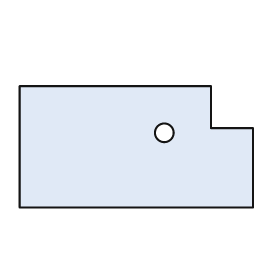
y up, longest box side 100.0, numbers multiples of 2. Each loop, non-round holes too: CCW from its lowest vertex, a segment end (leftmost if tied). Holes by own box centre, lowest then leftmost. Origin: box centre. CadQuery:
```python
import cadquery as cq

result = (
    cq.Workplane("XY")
    .moveTo(-50.0, -26.0)
    .lineTo(50.0, -26.0)
    .lineTo(50.0, 8.0)
    .lineTo(32.0, 8.0)
    .lineTo(32.0, 26.0)
    .lineTo(-50.0, 26.0)
    .close()
    .moveTo(12.0, 6.0)
    .circle(4.0)
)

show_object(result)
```